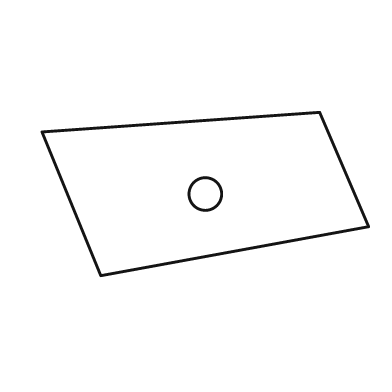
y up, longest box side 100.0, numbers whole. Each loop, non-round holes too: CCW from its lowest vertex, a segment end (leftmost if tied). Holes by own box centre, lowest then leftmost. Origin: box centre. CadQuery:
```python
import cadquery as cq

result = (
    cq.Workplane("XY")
    .moveTo(-32.0, -25.0)
    .lineTo(50.0, -10.0)
    .lineTo(35.0, 25.0)
    .lineTo(-50.0, 19.0)
    .close()
    .moveTo(0.0, 0.0)
    .circle(5.0)
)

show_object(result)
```